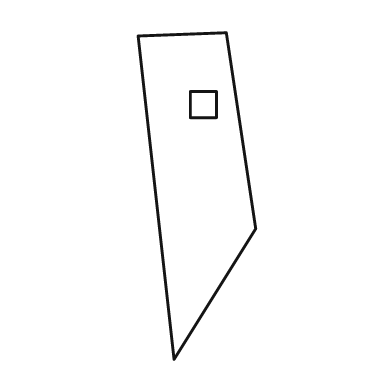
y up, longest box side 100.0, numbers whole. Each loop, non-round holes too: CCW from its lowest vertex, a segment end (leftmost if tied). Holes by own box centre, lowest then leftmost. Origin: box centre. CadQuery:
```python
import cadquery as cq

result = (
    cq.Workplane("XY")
    .moveTo(-7.0, -50.0)
    .lineTo(18.0, -10.0)
    .lineTo(9.0, 50.0)
    .lineTo(-18.0, 49.0)
    .close()
    .moveTo(-2.0, 24.0)
    .lineTo(6.0, 24.0)
    .lineTo(6.0, 32.0)
    .lineTo(-2.0, 32.0)
    .close()
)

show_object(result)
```